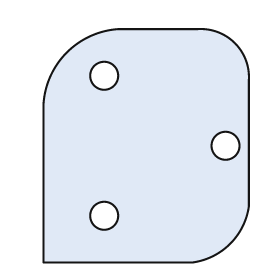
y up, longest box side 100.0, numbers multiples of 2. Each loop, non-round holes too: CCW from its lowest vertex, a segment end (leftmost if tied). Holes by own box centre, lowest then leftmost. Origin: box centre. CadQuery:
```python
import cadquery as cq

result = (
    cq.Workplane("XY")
    .moveTo(-44.0, -50.0)
    .lineTo(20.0, -50.0)
    .threePointArc((36.0, -42.0), (44.0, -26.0))
    .lineTo(44.0, 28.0)
    .threePointArc((38.0, 44.0), (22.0, 50.0))
    .lineTo(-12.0, 50.0)
    .threePointArc((-34.0, 40.0), (-44.0, 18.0))
    .close()
    .moveTo(-18.0, -30.0)
    .circle(6.0)
    .moveTo(34.0, 0.0)
    .circle(6.0)
    .moveTo(-18.0, 30.0)
    .circle(6.0)
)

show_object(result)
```